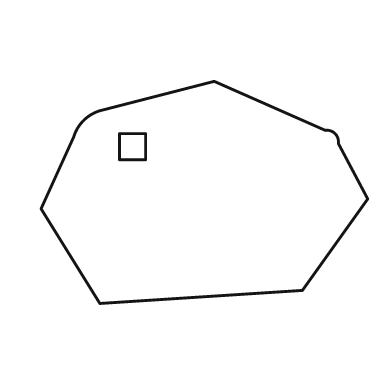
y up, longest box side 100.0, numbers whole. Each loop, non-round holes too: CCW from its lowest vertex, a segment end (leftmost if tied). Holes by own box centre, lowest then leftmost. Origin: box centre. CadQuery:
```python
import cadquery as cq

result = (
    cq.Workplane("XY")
    .moveTo(-32.0, -34.0)
    .lineTo(30.0, -30.0)
    .lineTo(50.0, -2.0)
    .lineTo(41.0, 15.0)
    .threePointArc((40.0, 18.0), (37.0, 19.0))
    .lineTo(3.0, 34.0)
    .lineTo(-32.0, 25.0)
    .threePointArc((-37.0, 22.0), (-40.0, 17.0))
    .lineTo(-50.0, -5.0)
    .close()
    .moveTo(-26.0, 10.0)
    .lineTo(-18.0, 10.0)
    .lineTo(-18.0, 18.0)
    .lineTo(-26.0, 18.0)
    .close()
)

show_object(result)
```